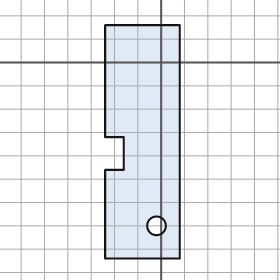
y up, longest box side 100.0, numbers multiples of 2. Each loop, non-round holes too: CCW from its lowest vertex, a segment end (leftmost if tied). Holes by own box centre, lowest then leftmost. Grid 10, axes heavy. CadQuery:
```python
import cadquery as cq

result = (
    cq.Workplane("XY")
    .moveTo(-24.0, -84.0)
    .lineTo(8.0, -84.0)
    .lineTo(8.0, 16.0)
    .lineTo(-24.0, 16.0)
    .lineTo(-24.0, -32.0)
    .lineTo(-16.0, -32.0)
    .lineTo(-16.0, -46.0)
    .lineTo(-24.0, -46.0)
    .close()
    .moveTo(-2.0, -70.0)
    .circle(4.0)
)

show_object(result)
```